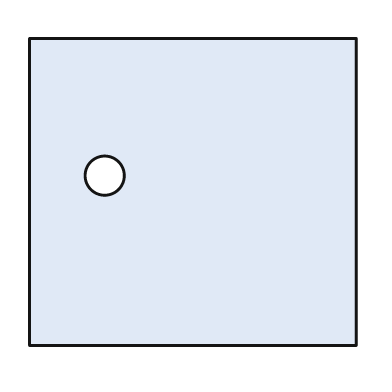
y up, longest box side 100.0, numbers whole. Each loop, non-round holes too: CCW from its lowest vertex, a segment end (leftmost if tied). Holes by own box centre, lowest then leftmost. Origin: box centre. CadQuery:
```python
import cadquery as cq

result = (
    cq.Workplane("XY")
    .moveTo(-50.0, -47.0)
    .lineTo(50.0, -47.0)
    .lineTo(50.0, 47.0)
    .lineTo(-50.0, 47.0)
    .close()
    .moveTo(-27.0, 5.0)
    .circle(6.0)
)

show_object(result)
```